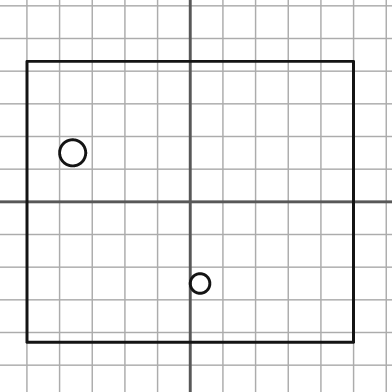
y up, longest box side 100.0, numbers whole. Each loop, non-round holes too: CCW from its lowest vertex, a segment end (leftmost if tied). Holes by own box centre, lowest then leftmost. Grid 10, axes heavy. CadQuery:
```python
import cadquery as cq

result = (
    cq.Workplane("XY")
    .moveTo(-50.0, -43.0)
    .lineTo(50.0, -43.0)
    .lineTo(50.0, 43.0)
    .lineTo(-50.0, 43.0)
    .close()
    .moveTo(3.0, -25.0)
    .circle(3.0)
    .moveTo(-36.0, 15.0)
    .circle(4.0)
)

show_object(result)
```